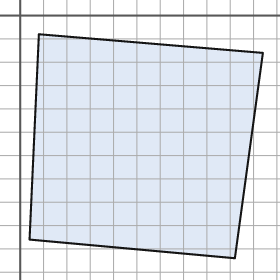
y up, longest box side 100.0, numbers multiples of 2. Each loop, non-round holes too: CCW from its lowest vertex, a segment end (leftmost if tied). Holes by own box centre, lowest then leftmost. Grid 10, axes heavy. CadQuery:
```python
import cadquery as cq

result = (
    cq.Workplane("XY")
    .moveTo(92.0, -104.0)
    .lineTo(104.0, -16.0)
    .lineTo(8.0, -8.0)
    .lineTo(4.0, -96.0)
    .close()
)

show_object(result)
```